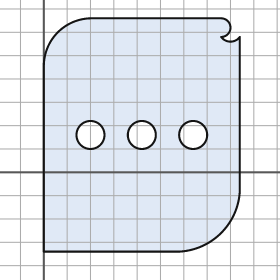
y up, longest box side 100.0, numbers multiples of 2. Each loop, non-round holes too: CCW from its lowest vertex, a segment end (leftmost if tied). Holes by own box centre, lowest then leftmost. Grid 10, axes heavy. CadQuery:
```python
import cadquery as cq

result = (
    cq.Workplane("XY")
    .moveTo(0.0, -34.0)
    .lineTo(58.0, -34.0)
    .threePointArc((76.0, -26.0), (84.0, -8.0))
    .lineTo(84.0, 58.0)
    .threePointArc((80.0, 56.0), (76.0, 58.0))
    .threePointArc((80.0, 62.0), (76.0, 66.0))
    .lineTo(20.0, 66.0)
    .threePointArc((6.0, 60.0), (0.0, 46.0))
    .close()
    .moveTo(20.0, 16.0)
    .circle(6.0)
    .moveTo(42.0, 16.0)
    .circle(6.0)
    .moveTo(64.0, 16.0)
    .circle(6.0)
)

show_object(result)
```